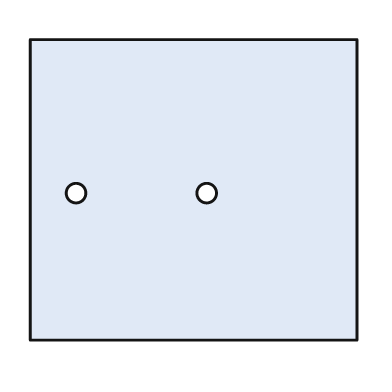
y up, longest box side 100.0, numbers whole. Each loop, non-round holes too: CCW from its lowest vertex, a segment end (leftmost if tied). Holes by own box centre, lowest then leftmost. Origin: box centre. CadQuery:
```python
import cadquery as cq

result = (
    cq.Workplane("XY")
    .moveTo(-50.0, -46.0)
    .lineTo(50.0, -46.0)
    .lineTo(50.0, 46.0)
    .lineTo(-50.0, 46.0)
    .close()
    .moveTo(-36.0, -1.0)
    .circle(3.0)
    .moveTo(4.0, -1.0)
    .circle(3.0)
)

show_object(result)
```